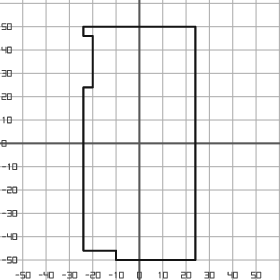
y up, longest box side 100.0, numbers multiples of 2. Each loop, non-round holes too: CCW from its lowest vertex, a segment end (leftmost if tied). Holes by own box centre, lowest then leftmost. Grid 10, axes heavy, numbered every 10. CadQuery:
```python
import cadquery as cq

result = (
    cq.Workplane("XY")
    .moveTo(-10.0, -50.0)
    .lineTo(24.0, -50.0)
    .lineTo(24.0, 50.0)
    .lineTo(-24.0, 50.0)
    .lineTo(-24.0, 46.0)
    .lineTo(-20.0, 46.0)
    .lineTo(-20.0, 24.0)
    .lineTo(-24.0, 24.0)
    .lineTo(-24.0, -46.0)
    .lineTo(-10.0, -46.0)
    .close()
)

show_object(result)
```